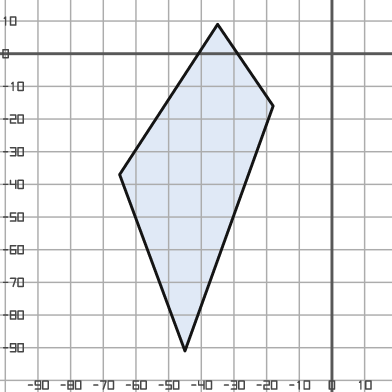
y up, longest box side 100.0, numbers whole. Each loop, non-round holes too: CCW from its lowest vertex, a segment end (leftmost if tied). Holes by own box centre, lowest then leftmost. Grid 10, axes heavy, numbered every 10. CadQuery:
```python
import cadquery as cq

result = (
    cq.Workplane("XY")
    .moveTo(-45.0, -91.0)
    .lineTo(-18.0, -16.0)
    .lineTo(-35.0, 9.0)
    .lineTo(-65.0, -37.0)
    .close()
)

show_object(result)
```